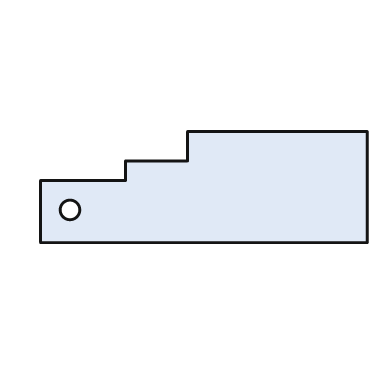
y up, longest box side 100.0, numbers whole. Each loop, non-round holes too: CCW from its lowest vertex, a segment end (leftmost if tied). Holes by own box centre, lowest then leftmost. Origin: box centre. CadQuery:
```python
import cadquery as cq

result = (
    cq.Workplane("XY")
    .moveTo(-50.0, -17.0)
    .lineTo(50.0, -17.0)
    .lineTo(50.0, 17.0)
    .lineTo(-5.0, 17.0)
    .lineTo(-5.0, 8.0)
    .lineTo(-24.0, 8.0)
    .lineTo(-24.0, 2.0)
    .lineTo(-50.0, 2.0)
    .close()
    .moveTo(-41.0, -7.0)
    .circle(3.0)
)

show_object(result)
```